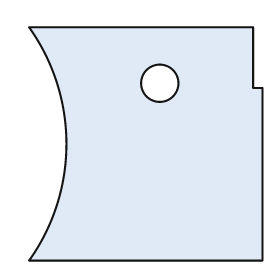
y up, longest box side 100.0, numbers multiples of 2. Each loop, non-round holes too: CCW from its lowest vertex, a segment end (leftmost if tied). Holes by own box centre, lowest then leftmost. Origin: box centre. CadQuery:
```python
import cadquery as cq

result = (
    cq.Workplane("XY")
    .moveTo(-50.0, -50.0)
    .lineTo(50.0, -50.0)
    .lineTo(50.0, 24.0)
    .lineTo(46.0, 24.0)
    .lineTo(46.0, 50.0)
    .lineTo(-50.0, 50.0)
    .threePointArc((-34.0, 0.0), (-50.0, -50.0))
    .close()
    .moveTo(6.0, 26.0)
    .circle(8.0)
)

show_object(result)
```